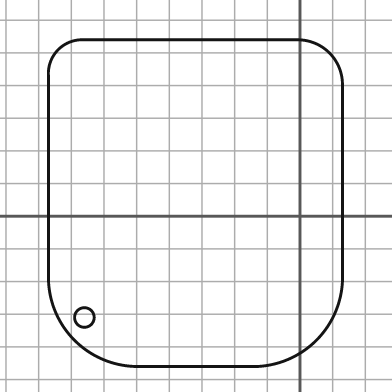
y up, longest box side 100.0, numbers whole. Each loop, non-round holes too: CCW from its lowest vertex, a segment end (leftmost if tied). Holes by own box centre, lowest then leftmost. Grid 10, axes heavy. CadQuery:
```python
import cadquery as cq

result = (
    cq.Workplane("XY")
    .moveTo(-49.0, -46.0)
    .lineTo(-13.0, -46.0)
    .threePointArc((5.0, -38.0), (13.0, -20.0))
    .lineTo(13.0, 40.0)
    .threePointArc((9.0, 50.0), (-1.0, 54.0))
    .lineTo(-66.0, 54.0)
    .threePointArc((-74.0, 51.0), (-77.0, 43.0))
    .lineTo(-77.0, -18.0)
    .threePointArc((-69.0, -38.0), (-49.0, -46.0))
    .close()
    .moveTo(-66.0, -31.0)
    .circle(3.0)
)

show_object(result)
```